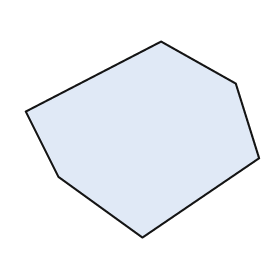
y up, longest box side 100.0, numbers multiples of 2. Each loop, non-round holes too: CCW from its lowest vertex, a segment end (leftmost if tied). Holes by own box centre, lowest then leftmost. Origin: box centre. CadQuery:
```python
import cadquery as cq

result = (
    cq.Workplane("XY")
    .moveTo(0.0, -42.0)
    .lineTo(50.0, -8.0)
    .lineTo(40.0, 24.0)
    .lineTo(8.0, 42.0)
    .lineTo(-50.0, 12.0)
    .lineTo(-36.0, -16.0)
    .close()
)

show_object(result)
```